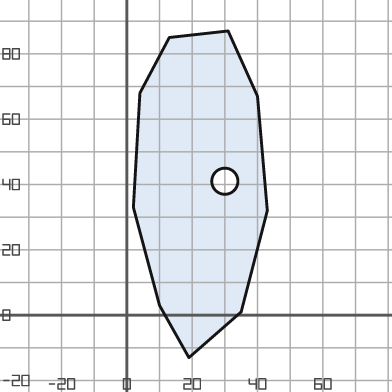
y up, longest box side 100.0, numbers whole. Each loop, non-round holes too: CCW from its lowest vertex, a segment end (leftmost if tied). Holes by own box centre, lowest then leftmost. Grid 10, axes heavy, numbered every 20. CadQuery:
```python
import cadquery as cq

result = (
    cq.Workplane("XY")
    .moveTo(19.0, -13.0)
    .lineTo(35.0, 1.0)
    .lineTo(43.0, 32.0)
    .lineTo(40.0, 67.0)
    .lineTo(31.0, 87.0)
    .lineTo(13.0, 85.0)
    .lineTo(4.0, 68.0)
    .lineTo(2.0, 33.0)
    .lineTo(10.0, 3.0)
    .close()
    .moveTo(30.0, 41.0)
    .circle(4.0)
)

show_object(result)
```